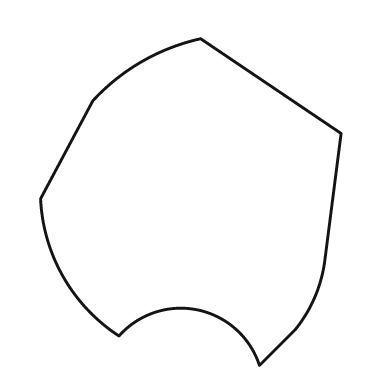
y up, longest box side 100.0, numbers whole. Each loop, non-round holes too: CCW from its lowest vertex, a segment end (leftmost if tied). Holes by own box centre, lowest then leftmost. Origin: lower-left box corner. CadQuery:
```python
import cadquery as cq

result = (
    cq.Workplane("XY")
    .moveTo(67.0, 0.0)
    .lineTo(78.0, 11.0)
    .threePointArc((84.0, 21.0), (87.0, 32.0))
    .lineTo(92.0, 71.0)
    .lineTo(49.0, 100.0)
    .threePointArc((31.0, 93.0), (16.0, 81.0))
    .lineTo(0.0, 51.0)
    .threePointArc((7.0, 27.0), (24.0, 9.0))
    .threePointArc((48.0, 17.0), (67.0, 0.0))
    .close()
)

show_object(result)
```